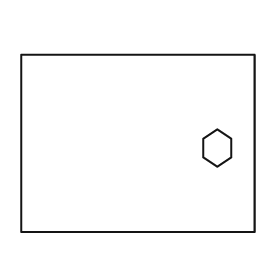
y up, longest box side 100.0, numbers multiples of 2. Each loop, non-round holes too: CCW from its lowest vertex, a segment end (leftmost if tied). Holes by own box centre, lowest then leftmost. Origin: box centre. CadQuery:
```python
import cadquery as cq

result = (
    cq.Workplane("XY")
    .moveTo(-50.0, -38.0)
    .lineTo(50.0, -38.0)
    .lineTo(50.0, 38.0)
    .lineTo(-50.0, 38.0)
    .close()
    .moveTo(34.0, -10.0)
    .lineTo(40.0, -6.0)
    .lineTo(40.0, 2.0)
    .lineTo(34.0, 6.0)
    .lineTo(28.0, 2.0)
    .lineTo(28.0, -6.0)
    .close()
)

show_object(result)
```